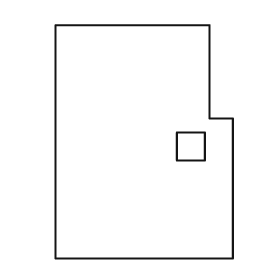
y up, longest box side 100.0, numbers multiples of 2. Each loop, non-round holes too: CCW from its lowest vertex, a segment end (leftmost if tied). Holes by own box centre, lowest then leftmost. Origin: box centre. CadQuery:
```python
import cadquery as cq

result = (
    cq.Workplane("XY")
    .moveTo(-38.0, -50.0)
    .lineTo(38.0, -50.0)
    .lineTo(38.0, 10.0)
    .lineTo(28.0, 10.0)
    .lineTo(28.0, 50.0)
    .lineTo(-38.0, 50.0)
    .close()
    .moveTo(14.0, -8.0)
    .lineTo(26.0, -8.0)
    .lineTo(26.0, 4.0)
    .lineTo(14.0, 4.0)
    .close()
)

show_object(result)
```